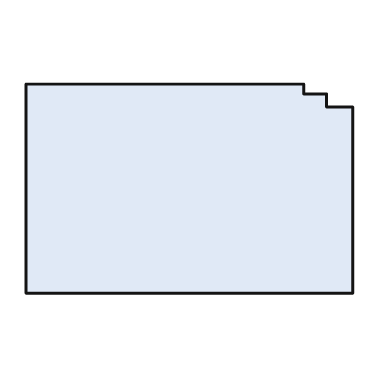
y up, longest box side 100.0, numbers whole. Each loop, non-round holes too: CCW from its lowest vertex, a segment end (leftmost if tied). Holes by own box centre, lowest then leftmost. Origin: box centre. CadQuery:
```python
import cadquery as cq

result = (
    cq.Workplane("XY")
    .moveTo(-50.0, -32.0)
    .lineTo(50.0, -32.0)
    .lineTo(50.0, 25.0)
    .lineTo(42.0, 25.0)
    .lineTo(42.0, 29.0)
    .lineTo(35.0, 29.0)
    .lineTo(35.0, 32.0)
    .lineTo(-50.0, 32.0)
    .close()
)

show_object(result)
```